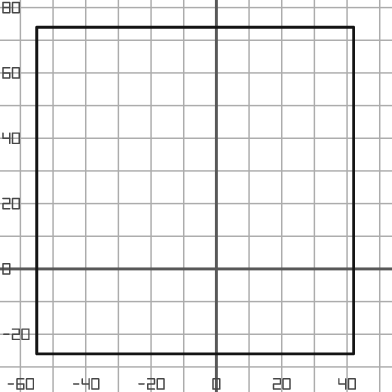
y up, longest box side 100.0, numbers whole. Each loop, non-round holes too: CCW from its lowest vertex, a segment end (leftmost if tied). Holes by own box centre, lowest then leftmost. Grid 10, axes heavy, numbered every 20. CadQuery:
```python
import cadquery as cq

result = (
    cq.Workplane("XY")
    .moveTo(-55.0, -26.0)
    .lineTo(42.0, -26.0)
    .lineTo(42.0, 74.0)
    .lineTo(-55.0, 74.0)
    .close()
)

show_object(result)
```